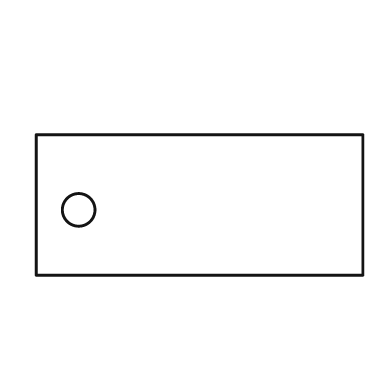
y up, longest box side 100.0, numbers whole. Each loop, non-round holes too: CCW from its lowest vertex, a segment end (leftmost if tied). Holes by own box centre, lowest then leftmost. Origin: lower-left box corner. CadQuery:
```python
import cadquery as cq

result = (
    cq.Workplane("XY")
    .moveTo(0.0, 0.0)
    .lineTo(100.0, 0.0)
    .lineTo(100.0, 43.0)
    .lineTo(0.0, 43.0)
    .close()
    .moveTo(13.0, 20.0)
    .circle(5.0)
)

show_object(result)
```